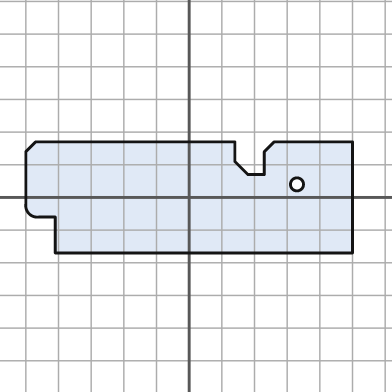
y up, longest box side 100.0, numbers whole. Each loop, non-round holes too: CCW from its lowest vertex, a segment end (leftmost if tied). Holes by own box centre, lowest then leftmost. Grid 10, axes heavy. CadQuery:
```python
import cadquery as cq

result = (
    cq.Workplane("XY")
    .moveTo(-41.0, -17.0)
    .lineTo(50.0, -17.0)
    .lineTo(50.0, 17.0)
    .lineTo(26.0, 17.0)
    .lineTo(23.0, 14.0)
    .lineTo(23.0, 7.0)
    .lineTo(18.0, 7.0)
    .lineTo(14.0, 11.0)
    .lineTo(14.0, 17.0)
    .lineTo(-47.0, 17.0)
    .lineTo(-50.0, 14.0)
    .lineTo(-50.0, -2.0)
    .threePointArc((-49.0, -5.0), (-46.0, -6.0))
    .lineTo(-41.0, -6.0)
    .close()
    .moveTo(33.0, 4.0)
    .circle(2.0)
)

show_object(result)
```